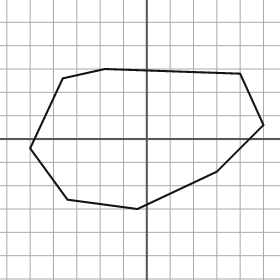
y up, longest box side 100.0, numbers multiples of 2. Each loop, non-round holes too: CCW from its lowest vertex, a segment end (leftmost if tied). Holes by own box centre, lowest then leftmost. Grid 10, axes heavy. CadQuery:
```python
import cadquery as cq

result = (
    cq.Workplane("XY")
    .moveTo(-4.0, -30.0)
    .lineTo(30.0, -14.0)
    .lineTo(50.0, 6.0)
    .lineTo(40.0, 28.0)
    .lineTo(-18.0, 30.0)
    .lineTo(-36.0, 26.0)
    .lineTo(-50.0, -4.0)
    .lineTo(-34.0, -26.0)
    .close()
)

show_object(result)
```